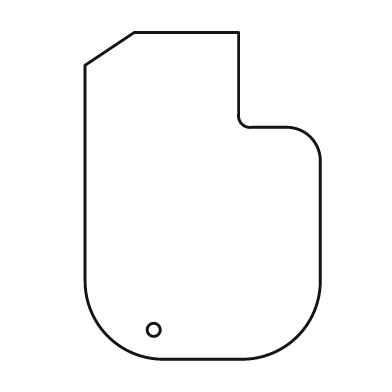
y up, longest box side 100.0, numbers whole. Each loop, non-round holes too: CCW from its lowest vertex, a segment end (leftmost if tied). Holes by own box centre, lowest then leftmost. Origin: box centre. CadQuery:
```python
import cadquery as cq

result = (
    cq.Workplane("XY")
    .moveTo(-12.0, -50.0)
    .lineTo(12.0, -50.0)
    .threePointArc((29.0, -43.0), (36.0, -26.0))
    .lineTo(36.0, 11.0)
    .threePointArc((33.0, 18.0), (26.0, 21.0))
    .lineTo(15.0, 21.0)
    .threePointArc((12.0, 22.0), (11.0, 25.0))
    .lineTo(11.0, 50.0)
    .lineTo(-21.0, 50.0)
    .lineTo(-36.0, 40.0)
    .lineTo(-36.0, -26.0)
    .threePointArc((-29.0, -43.0), (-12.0, -50.0))
    .close()
    .moveTo(-15.0, -41.0)
    .circle(2.0)
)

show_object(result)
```